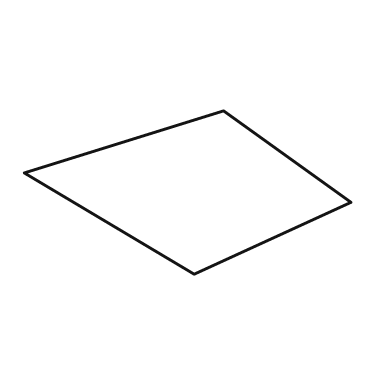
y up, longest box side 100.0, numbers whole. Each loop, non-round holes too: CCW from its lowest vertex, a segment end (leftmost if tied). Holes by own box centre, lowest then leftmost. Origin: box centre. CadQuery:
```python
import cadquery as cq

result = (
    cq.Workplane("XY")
    .moveTo(2.0, -25.0)
    .lineTo(50.0, -3.0)
    .lineTo(11.0, 25.0)
    .lineTo(-50.0, 6.0)
    .close()
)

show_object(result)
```